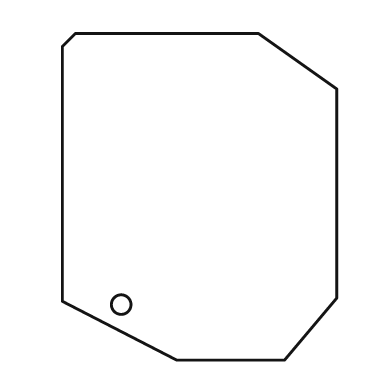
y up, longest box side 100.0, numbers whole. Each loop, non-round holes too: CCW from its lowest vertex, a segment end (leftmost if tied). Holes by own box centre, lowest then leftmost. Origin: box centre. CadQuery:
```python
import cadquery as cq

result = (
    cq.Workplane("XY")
    .moveTo(-7.0, -50.0)
    .lineTo(26.0, -50.0)
    .lineTo(42.0, -31.0)
    .lineTo(42.0, 33.0)
    .lineTo(18.0, 50.0)
    .lineTo(-38.0, 50.0)
    .lineTo(-42.0, 46.0)
    .lineTo(-42.0, -32.0)
    .close()
    .moveTo(-24.0, -33.0)
    .circle(3.0)
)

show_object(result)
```